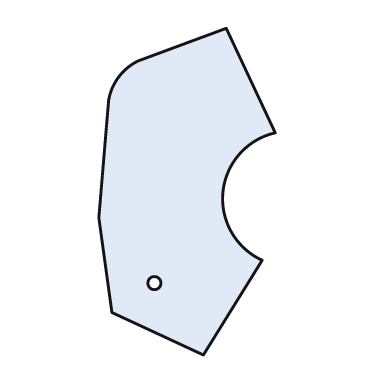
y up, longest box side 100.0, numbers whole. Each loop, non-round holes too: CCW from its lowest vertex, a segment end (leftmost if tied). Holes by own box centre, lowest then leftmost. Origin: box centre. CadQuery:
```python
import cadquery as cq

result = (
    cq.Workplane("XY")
    .moveTo(5.0, -50.0)
    .lineTo(23.0, -21.0)
    .threePointArc((11.0, 0.0), (27.0, 18.0))
    .lineTo(12.0, 50.0)
    .lineTo(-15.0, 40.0)
    .threePointArc((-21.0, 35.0), (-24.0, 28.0))
    .lineTo(-27.0, -8.0)
    .lineTo(-23.0, -37.0)
    .close()
    .moveTo(-10.0, -28.0)
    .circle(2.0)
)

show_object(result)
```